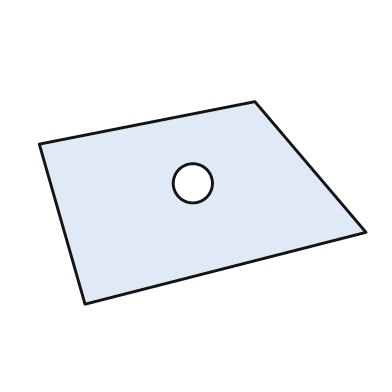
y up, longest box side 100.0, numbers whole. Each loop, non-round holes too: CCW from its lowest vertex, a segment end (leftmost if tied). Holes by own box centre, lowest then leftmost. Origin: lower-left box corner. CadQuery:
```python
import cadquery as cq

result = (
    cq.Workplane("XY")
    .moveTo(14.0, 0.0)
    .lineTo(100.0, 22.0)
    .lineTo(66.0, 62.0)
    .lineTo(0.0, 49.0)
    .close()
    .moveTo(47.0, 37.0)
    .circle(6.0)
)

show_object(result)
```